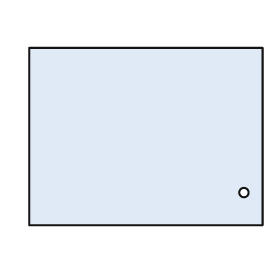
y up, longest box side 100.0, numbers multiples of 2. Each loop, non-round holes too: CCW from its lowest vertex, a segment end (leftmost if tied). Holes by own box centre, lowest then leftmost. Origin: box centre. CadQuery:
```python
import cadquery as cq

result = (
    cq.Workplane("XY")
    .moveTo(-50.0, -38.0)
    .lineTo(50.0, -38.0)
    .lineTo(50.0, 38.0)
    .lineTo(-50.0, 38.0)
    .close()
    .moveTo(42.0, -24.0)
    .circle(2.0)
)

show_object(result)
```